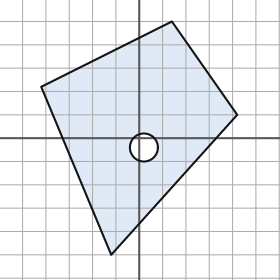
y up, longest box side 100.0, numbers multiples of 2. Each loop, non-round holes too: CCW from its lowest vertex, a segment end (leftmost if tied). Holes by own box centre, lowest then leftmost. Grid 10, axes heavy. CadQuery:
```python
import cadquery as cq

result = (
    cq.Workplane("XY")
    .moveTo(-12.0, -50.0)
    .lineTo(42.0, 10.0)
    .lineTo(14.0, 50.0)
    .lineTo(-42.0, 22.0)
    .close()
    .moveTo(2.0, -4.0)
    .circle(6.0)
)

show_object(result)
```